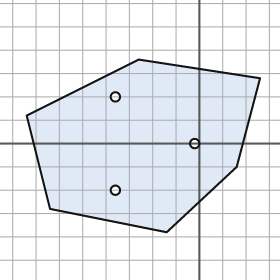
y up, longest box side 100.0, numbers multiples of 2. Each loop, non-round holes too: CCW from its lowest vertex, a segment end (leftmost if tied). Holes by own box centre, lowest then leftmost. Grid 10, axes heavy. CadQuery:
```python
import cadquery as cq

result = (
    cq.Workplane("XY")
    .moveTo(-14.0, -38.0)
    .lineTo(16.0, -10.0)
    .lineTo(26.0, 28.0)
    .lineTo(-26.0, 36.0)
    .lineTo(-74.0, 12.0)
    .lineTo(-64.0, -28.0)
    .close()
    .moveTo(-36.0, -20.0)
    .circle(2.0)
    .moveTo(-2.0, 0.0)
    .circle(2.0)
    .moveTo(-36.0, 20.0)
    .circle(2.0)
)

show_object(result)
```